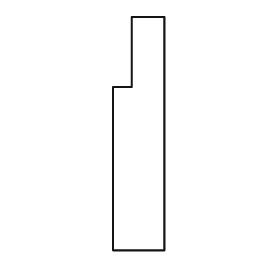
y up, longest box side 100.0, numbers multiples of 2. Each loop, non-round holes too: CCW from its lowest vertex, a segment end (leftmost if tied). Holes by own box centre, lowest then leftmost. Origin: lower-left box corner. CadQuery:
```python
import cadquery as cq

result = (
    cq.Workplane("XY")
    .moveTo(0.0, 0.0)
    .lineTo(22.0, 0.0)
    .lineTo(22.0, 100.0)
    .lineTo(8.0, 100.0)
    .lineTo(8.0, 70.0)
    .lineTo(0.0, 70.0)
    .close()
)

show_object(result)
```